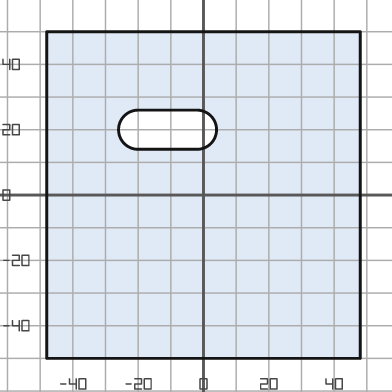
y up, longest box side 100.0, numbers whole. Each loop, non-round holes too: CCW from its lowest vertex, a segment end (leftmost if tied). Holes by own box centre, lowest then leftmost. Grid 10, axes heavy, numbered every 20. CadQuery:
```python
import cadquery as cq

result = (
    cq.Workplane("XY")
    .moveTo(-48.0, -50.0)
    .lineTo(48.0, -50.0)
    .lineTo(48.0, 50.0)
    .lineTo(-48.0, 50.0)
    .close()
    .moveTo(-20.0, 14.0)
    .lineTo(-2.0, 14.0)
    .threePointArc((4.0, 20.0), (-2.0, 26.0))
    .lineTo(-20.0, 26.0)
    .threePointArc((-26.0, 20.0), (-20.0, 14.0))
    .close()
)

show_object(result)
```